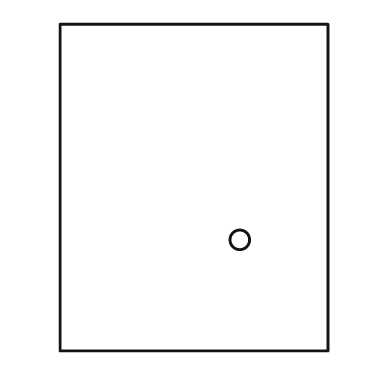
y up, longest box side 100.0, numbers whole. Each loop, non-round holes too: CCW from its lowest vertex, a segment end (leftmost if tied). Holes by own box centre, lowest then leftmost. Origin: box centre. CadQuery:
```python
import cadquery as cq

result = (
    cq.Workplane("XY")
    .moveTo(-41.0, -50.0)
    .lineTo(41.0, -50.0)
    .lineTo(41.0, 50.0)
    .lineTo(-41.0, 50.0)
    .close()
    .moveTo(14.0, -16.0)
    .circle(3.0)
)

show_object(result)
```